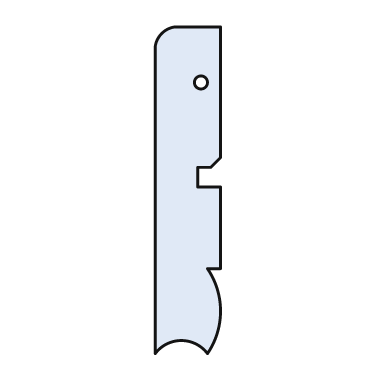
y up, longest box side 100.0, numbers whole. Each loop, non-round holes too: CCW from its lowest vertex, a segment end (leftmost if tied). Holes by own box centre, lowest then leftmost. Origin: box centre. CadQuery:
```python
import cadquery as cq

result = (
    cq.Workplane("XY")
    .moveTo(-10.0, -50.0)
    .threePointArc((-2.0, -46.0), (6.0, -50.0))
    .threePointArc((10.0, -37.0), (6.0, -24.0))
    .lineTo(10.0, -24.0)
    .lineTo(10.0, 1.0)
    .lineTo(3.0, 1.0)
    .lineTo(3.0, 7.0)
    .lineTo(7.0, 7.0)
    .lineTo(10.0, 10.0)
    .lineTo(10.0, 50.0)
    .lineTo(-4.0, 50.0)
    .threePointArc((-8.0, 48.0), (-10.0, 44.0))
    .close()
    .moveTo(4.0, 33.0)
    .circle(2.0)
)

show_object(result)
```